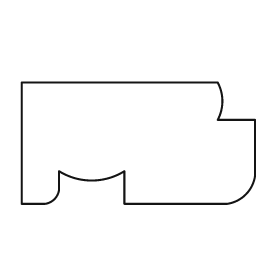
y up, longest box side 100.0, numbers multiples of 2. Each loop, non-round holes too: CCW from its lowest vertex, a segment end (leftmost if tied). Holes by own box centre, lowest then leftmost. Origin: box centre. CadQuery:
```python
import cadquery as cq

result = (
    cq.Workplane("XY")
    .moveTo(-50.0, -26.0)
    .lineTo(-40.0, -26.0)
    .threePointArc((-36.0, -24.0), (-34.0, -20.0))
    .lineTo(-34.0, -12.0)
    .threePointArc((-20.0, -16.0), (-6.0, -12.0))
    .lineTo(-6.0, -26.0)
    .lineTo(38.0, -26.0)
    .threePointArc((46.0, -22.0), (50.0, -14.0))
    .lineTo(50.0, 10.0)
    .lineTo(34.0, 10.0)
    .threePointArc((36.0, 18.0), (34.0, 26.0))
    .lineTo(-50.0, 26.0)
    .close()
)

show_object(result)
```